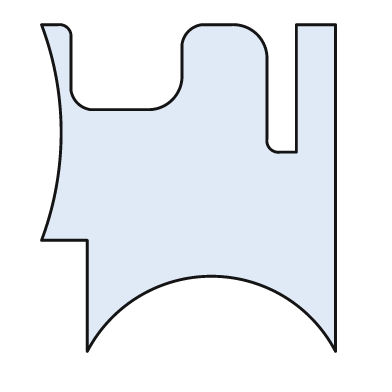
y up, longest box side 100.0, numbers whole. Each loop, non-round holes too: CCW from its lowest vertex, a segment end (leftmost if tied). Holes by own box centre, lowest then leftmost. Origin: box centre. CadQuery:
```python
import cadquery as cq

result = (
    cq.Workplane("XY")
    .moveTo(-31.0, -50.0)
    .threePointArc((7.0, -27.0), (45.0, -50.0))
    .lineTo(45.0, 50.0)
    .lineTo(33.0, 50.0)
    .lineTo(33.0, 11.0)
    .lineTo(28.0, 11.0)
    .threePointArc((25.0, 12.0), (24.0, 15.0))
    .lineTo(24.0, 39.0)
    .threePointArc((21.0, 47.0), (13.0, 50.0))
    .lineTo(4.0, 50.0)
    .threePointArc((0.0, 48.0), (-2.0, 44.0))
    .lineTo(-2.0, 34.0)
    .threePointArc((-5.0, 27.0), (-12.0, 24.0))
    .lineTo(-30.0, 24.0)
    .threePointArc((-34.0, 26.0), (-36.0, 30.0))
    .lineTo(-36.0, 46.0)
    .threePointArc((-37.0, 49.0), (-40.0, 50.0))
    .lineTo(-45.0, 50.0)
    .threePointArc((-39.0, 17.0), (-45.0, -16.0))
    .lineTo(-31.0, -16.0)
    .close()
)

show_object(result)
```